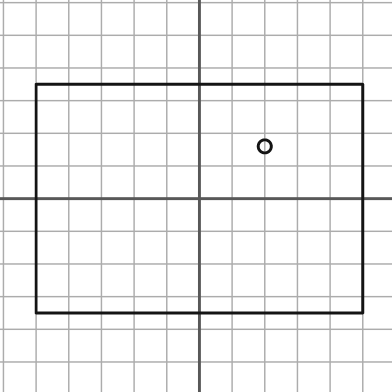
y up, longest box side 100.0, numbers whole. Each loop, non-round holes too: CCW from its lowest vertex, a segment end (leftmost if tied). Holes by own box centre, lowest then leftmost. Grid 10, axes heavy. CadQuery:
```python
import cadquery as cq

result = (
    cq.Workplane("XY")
    .moveTo(-50.0, -35.0)
    .lineTo(50.0, -35.0)
    .lineTo(50.0, 35.0)
    .lineTo(-50.0, 35.0)
    .close()
    .moveTo(20.0, 16.0)
    .circle(2.0)
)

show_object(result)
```